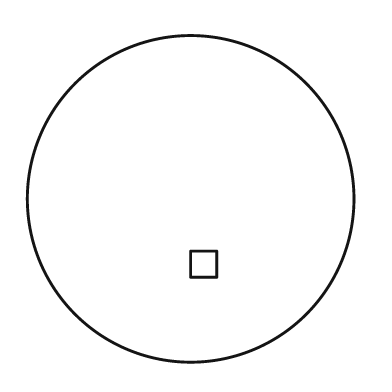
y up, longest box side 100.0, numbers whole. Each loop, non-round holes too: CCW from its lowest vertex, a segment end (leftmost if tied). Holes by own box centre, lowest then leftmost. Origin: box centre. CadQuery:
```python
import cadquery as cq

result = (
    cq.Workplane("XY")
    .moveTo(0.0, 0.0)
    .circle(50.0)
    .moveTo(0.0, -24.0)
    .lineTo(8.0, -24.0)
    .lineTo(8.0, -16.0)
    .lineTo(0.0, -16.0)
    .close()
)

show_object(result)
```